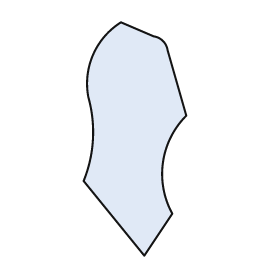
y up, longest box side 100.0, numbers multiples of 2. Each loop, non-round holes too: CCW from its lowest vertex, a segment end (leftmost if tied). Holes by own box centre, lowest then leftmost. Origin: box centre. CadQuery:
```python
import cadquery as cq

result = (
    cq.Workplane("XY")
    .moveTo(4.0, -50.0)
    .lineTo(16.0, -32.0)
    .threePointArc((12.0, -10.0), (22.0, 10.0))
    .lineTo(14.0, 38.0)
    .threePointArc((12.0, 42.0), (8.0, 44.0))
    .lineTo(-6.0, 50.0)
    .threePointArc((-18.0, 36.0), (-20.0, 18.0))
    .threePointArc((-18.0, 0.0), (-22.0, -18.0))
    .close()
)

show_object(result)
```